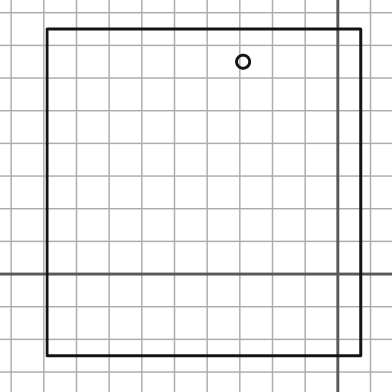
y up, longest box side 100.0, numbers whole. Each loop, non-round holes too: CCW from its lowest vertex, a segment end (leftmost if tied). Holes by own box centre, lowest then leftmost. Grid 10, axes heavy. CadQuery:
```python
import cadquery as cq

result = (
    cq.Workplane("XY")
    .moveTo(-89.0, -25.0)
    .lineTo(7.0, -25.0)
    .lineTo(7.0, 75.0)
    .lineTo(-89.0, 75.0)
    .close()
    .moveTo(-29.0, 65.0)
    .circle(2.0)
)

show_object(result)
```